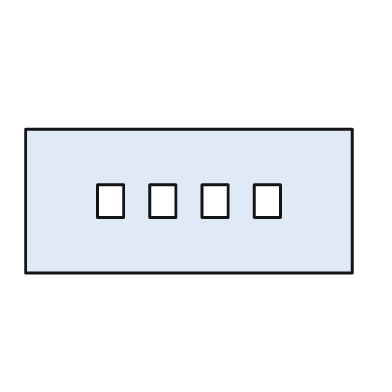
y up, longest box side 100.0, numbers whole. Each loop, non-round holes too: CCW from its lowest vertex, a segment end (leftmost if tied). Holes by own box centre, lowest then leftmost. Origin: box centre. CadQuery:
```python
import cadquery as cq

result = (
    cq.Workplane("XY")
    .moveTo(-50.0, -22.0)
    .lineTo(50.0, -22.0)
    .lineTo(50.0, 22.0)
    .lineTo(-50.0, 22.0)
    .close()
    .moveTo(-28.0, -5.0)
    .lineTo(-20.0, -5.0)
    .lineTo(-20.0, 5.0)
    .lineTo(-28.0, 5.0)
    .close()
    .moveTo(-12.0, -5.0)
    .lineTo(-4.0, -5.0)
    .lineTo(-4.0, 5.0)
    .lineTo(-12.0, 5.0)
    .close()
    .moveTo(4.0, -5.0)
    .lineTo(12.0, -5.0)
    .lineTo(12.0, 5.0)
    .lineTo(4.0, 5.0)
    .close()
    .moveTo(20.0, -5.0)
    .lineTo(28.0, -5.0)
    .lineTo(28.0, 5.0)
    .lineTo(20.0, 5.0)
    .close()
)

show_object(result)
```